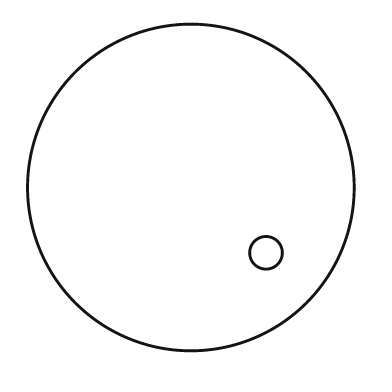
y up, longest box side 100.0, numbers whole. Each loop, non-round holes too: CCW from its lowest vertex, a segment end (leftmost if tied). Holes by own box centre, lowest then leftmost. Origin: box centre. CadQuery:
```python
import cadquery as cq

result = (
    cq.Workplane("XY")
    .moveTo(0.0, 0.0)
    .circle(50.0)
    .moveTo(23.0, -20.0)
    .circle(5.0)
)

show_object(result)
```